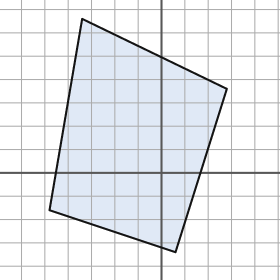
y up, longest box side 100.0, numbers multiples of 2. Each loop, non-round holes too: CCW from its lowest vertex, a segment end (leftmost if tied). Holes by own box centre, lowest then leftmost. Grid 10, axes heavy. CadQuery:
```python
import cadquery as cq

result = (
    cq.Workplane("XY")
    .moveTo(6.0, -34.0)
    .lineTo(28.0, 36.0)
    .lineTo(-34.0, 66.0)
    .lineTo(-48.0, -16.0)
    .close()
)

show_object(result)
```